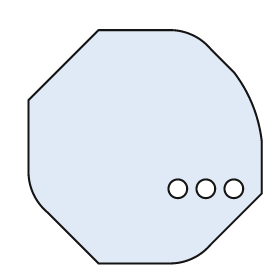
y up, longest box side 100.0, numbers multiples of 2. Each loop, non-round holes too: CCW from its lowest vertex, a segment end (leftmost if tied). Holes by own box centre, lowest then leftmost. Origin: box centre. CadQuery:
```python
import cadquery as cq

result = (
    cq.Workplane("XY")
    .moveTo(-20.0, -50.0)
    .lineTo(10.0, -50.0)
    .threePointArc((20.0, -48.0), (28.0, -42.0))
    .lineTo(50.0, -20.0)
    .lineTo(50.0, 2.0)
    .threePointArc((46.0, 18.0), (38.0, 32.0))
    .lineTo(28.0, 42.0)
    .threePointArc((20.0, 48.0), (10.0, 50.0))
    .lineTo(-20.0, 50.0)
    .lineTo(-50.0, 20.0)
    .lineTo(-50.0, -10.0)
    .threePointArc((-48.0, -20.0), (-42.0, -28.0))
    .close()
    .moveTo(14.0, -18.0)
    .circle(4.0)
    .moveTo(26.0, -18.0)
    .circle(4.0)
    .moveTo(38.0, -18.0)
    .circle(4.0)
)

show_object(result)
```